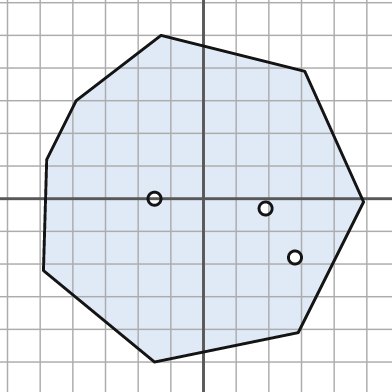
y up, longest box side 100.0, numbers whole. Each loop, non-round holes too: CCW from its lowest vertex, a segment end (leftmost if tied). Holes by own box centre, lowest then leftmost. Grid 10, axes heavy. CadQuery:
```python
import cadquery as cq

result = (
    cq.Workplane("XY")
    .moveTo(-15.0, -50.0)
    .lineTo(29.0, -41.0)
    .lineTo(49.0, -1.0)
    .lineTo(31.0, 39.0)
    .lineTo(-13.0, 50.0)
    .lineTo(-39.0, 30.0)
    .lineTo(-48.0, 12.0)
    .lineTo(-49.0, -22.0)
    .close()
    .moveTo(28.0, -18.0)
    .circle(2.0)
    .moveTo(19.0, -3.0)
    .circle(2.0)
    .moveTo(-15.0, 0.0)
    .circle(2.0)
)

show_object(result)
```